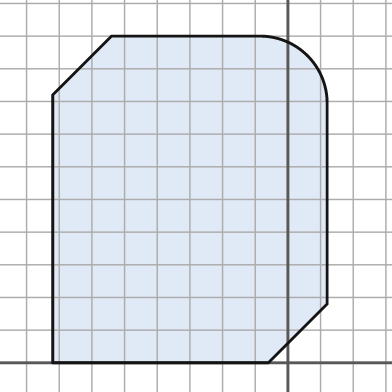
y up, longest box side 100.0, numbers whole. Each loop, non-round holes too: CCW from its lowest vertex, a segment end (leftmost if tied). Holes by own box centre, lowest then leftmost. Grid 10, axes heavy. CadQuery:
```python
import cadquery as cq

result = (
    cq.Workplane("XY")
    .moveTo(-72.0, 0.0)
    .lineTo(-6.0, 0.0)
    .lineTo(12.0, 18.0)
    .lineTo(12.0, 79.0)
    .threePointArc((6.0, 94.0), (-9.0, 100.0))
    .lineTo(-54.0, 100.0)
    .lineTo(-72.0, 82.0)
    .close()
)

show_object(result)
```